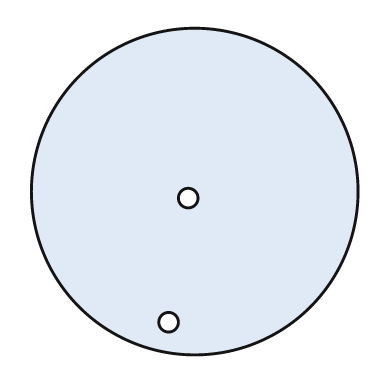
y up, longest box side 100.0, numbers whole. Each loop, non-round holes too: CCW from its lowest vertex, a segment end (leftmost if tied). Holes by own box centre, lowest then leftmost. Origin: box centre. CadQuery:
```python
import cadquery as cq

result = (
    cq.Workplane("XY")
    .moveTo(0.0, 0.0)
    .circle(50.0)
    .moveTo(-8.0, -40.0)
    .circle(3.0)
    .moveTo(-2.0, -2.0)
    .circle(3.0)
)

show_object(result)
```